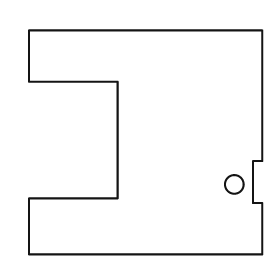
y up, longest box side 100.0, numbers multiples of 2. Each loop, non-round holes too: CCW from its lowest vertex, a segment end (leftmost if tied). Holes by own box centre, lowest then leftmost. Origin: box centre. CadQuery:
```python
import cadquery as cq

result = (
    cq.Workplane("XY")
    .moveTo(-50.0, -48.0)
    .lineTo(50.0, -48.0)
    .lineTo(50.0, -26.0)
    .lineTo(46.0, -26.0)
    .lineTo(46.0, -8.0)
    .lineTo(50.0, -8.0)
    .lineTo(50.0, 48.0)
    .lineTo(-50.0, 48.0)
    .lineTo(-50.0, 26.0)
    .lineTo(-12.0, 26.0)
    .lineTo(-12.0, -24.0)
    .lineTo(-50.0, -24.0)
    .close()
    .moveTo(38.0, -18.0)
    .circle(4.0)
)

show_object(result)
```